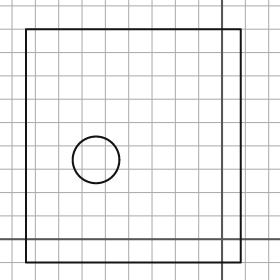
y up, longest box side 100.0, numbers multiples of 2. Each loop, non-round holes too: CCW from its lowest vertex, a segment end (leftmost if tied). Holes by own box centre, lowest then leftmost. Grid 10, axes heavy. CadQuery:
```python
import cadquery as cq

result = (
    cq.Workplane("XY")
    .moveTo(-84.0, -10.0)
    .lineTo(8.0, -10.0)
    .lineTo(8.0, 90.0)
    .lineTo(-84.0, 90.0)
    .close()
    .moveTo(-54.0, 34.0)
    .circle(10.0)
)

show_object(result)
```